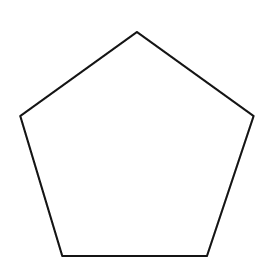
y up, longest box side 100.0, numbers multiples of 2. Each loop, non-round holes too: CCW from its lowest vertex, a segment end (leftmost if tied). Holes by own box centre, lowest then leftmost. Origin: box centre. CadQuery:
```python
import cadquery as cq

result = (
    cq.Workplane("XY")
    .moveTo(-32.0, -48.0)
    .lineTo(30.0, -48.0)
    .lineTo(50.0, 12.0)
    .lineTo(0.0, 48.0)
    .lineTo(-50.0, 12.0)
    .close()
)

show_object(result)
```